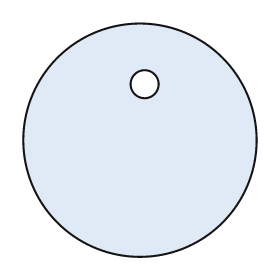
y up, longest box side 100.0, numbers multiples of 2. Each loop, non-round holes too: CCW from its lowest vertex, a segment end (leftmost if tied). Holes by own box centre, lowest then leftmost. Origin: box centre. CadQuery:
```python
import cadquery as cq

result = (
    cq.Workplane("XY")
    .moveTo(0.0, 0.0)
    .circle(50.0)
    .moveTo(2.0, 24.0)
    .circle(6.0)
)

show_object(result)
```